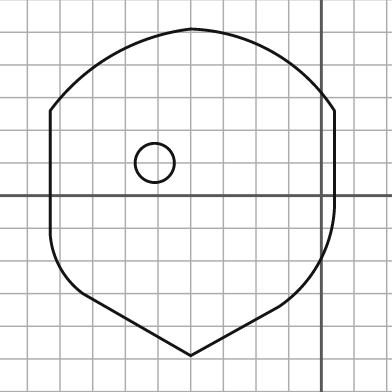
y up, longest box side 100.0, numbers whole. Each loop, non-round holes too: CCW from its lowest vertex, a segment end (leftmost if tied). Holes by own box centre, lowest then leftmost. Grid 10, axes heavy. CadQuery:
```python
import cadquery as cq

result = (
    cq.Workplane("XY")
    .moveTo(-40.0, -49.0)
    .lineTo(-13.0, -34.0)
    .threePointArc((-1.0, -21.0), (4.0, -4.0))
    .lineTo(4.0, 26.0)
    .threePointArc((-15.0, 44.0), (-40.0, 51.0))
    .threePointArc((-64.0, 43.0), (-83.0, 26.0))
    .lineTo(-83.0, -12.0)
    .threePointArc((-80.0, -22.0), (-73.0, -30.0))
    .close()
    .moveTo(-51.0, 10.0)
    .circle(6.0)
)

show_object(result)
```